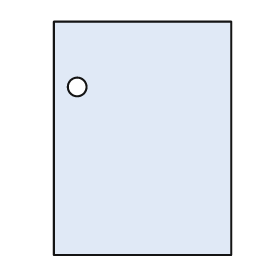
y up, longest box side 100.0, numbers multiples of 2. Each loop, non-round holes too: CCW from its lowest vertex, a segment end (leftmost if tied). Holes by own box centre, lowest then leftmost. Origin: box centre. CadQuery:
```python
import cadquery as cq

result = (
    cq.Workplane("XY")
    .moveTo(-38.0, -50.0)
    .lineTo(38.0, -50.0)
    .lineTo(38.0, 50.0)
    .lineTo(-38.0, 50.0)
    .close()
    .moveTo(-28.0, 22.0)
    .circle(4.0)
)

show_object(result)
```